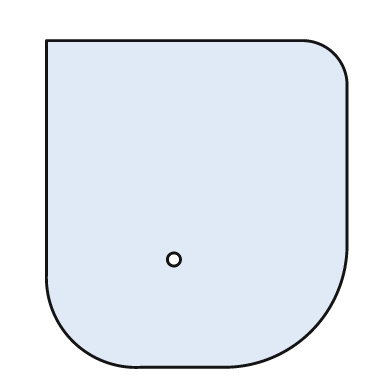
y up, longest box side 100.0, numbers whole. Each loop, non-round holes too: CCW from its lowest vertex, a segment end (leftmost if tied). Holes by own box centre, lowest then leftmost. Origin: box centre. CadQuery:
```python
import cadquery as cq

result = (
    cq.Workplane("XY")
    .moveTo(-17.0, -50.0)
    .lineTo(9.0, -50.0)
    .threePointArc((35.0, -39.0), (46.0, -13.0))
    .lineTo(46.0, 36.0)
    .threePointArc((42.0, 46.0), (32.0, 50.0))
    .lineTo(-46.0, 50.0)
    .lineTo(-46.0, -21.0)
    .threePointArc((-38.0, -42.0), (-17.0, -50.0))
    .close()
    .moveTo(-7.0, -17.0)
    .circle(2.0)
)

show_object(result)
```